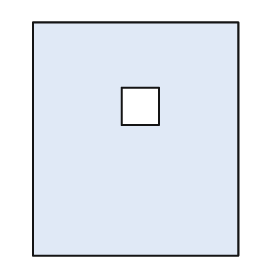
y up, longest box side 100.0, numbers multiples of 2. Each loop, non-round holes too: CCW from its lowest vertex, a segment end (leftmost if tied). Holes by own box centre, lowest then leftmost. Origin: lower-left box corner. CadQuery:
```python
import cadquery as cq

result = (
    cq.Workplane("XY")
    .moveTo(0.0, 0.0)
    .lineTo(88.0, 0.0)
    .lineTo(88.0, 100.0)
    .lineTo(0.0, 100.0)
    .close()
    .moveTo(38.0, 56.0)
    .lineTo(54.0, 56.0)
    .lineTo(54.0, 72.0)
    .lineTo(38.0, 72.0)
    .close()
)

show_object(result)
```